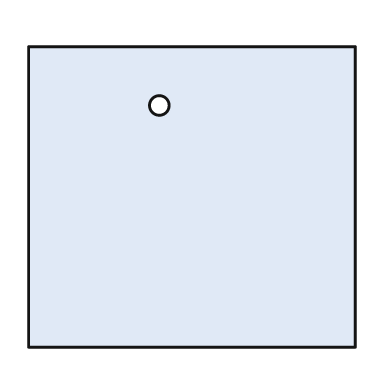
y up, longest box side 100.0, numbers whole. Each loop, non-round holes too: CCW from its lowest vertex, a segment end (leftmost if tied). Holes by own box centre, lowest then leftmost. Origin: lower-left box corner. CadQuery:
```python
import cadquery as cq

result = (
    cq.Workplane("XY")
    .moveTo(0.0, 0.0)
    .lineTo(100.0, 0.0)
    .lineTo(100.0, 92.0)
    .lineTo(0.0, 92.0)
    .close()
    .moveTo(40.0, 74.0)
    .circle(3.0)
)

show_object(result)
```